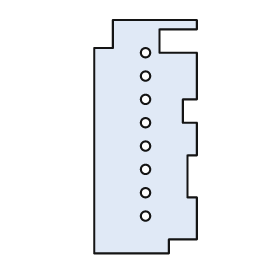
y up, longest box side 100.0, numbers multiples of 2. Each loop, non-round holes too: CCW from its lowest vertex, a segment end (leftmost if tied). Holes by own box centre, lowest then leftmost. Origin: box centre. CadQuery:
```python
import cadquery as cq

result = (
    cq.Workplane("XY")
    .moveTo(-22.0, -50.0)
    .lineTo(10.0, -50.0)
    .lineTo(10.0, -44.0)
    .lineTo(22.0, -44.0)
    .lineTo(22.0, -26.0)
    .lineTo(18.0, -26.0)
    .lineTo(18.0, -8.0)
    .lineTo(22.0, -8.0)
    .lineTo(22.0, 6.0)
    .lineTo(16.0, 6.0)
    .lineTo(16.0, 16.0)
    .lineTo(22.0, 16.0)
    .lineTo(22.0, 36.0)
    .lineTo(6.0, 36.0)
    .lineTo(6.0, 46.0)
    .lineTo(22.0, 46.0)
    .lineTo(22.0, 50.0)
    .lineTo(-14.0, 50.0)
    .lineTo(-14.0, 38.0)
    .lineTo(-22.0, 38.0)
    .close()
    .moveTo(0.0, -34.0)
    .circle(2.0)
    .moveTo(0.0, -24.0)
    .circle(2.0)
    .moveTo(0.0, -14.0)
    .circle(2.0)
    .moveTo(0.0, -4.0)
    .circle(2.0)
    .moveTo(0.0, 6.0)
    .circle(2.0)
    .moveTo(0.0, 16.0)
    .circle(2.0)
    .moveTo(0.0, 26.0)
    .circle(2.0)
    .moveTo(0.0, 36.0)
    .circle(2.0)
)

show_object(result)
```